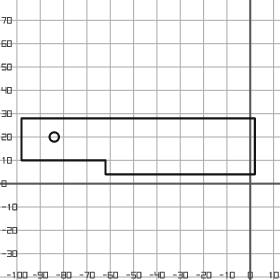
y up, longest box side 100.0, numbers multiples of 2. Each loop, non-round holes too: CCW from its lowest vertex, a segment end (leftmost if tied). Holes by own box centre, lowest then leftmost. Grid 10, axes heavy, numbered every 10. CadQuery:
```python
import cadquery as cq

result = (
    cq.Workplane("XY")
    .moveTo(-62.0, 4.0)
    .lineTo(2.0, 4.0)
    .lineTo(2.0, 28.0)
    .lineTo(-98.0, 28.0)
    .lineTo(-98.0, 10.0)
    .lineTo(-62.0, 10.0)
    .close()
    .moveTo(-84.0, 20.0)
    .circle(2.0)
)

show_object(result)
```